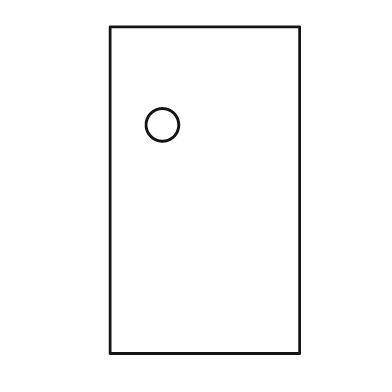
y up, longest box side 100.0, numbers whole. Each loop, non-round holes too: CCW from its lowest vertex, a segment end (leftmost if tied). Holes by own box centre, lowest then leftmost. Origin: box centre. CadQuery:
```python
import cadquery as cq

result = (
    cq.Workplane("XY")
    .moveTo(-29.0, -50.0)
    .lineTo(29.0, -50.0)
    .lineTo(29.0, 50.0)
    .lineTo(-29.0, 50.0)
    .close()
    .moveTo(-13.0, 20.0)
    .circle(5.0)
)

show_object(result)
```